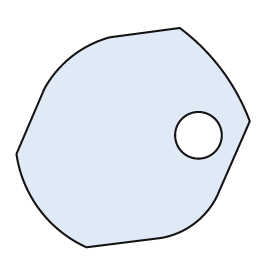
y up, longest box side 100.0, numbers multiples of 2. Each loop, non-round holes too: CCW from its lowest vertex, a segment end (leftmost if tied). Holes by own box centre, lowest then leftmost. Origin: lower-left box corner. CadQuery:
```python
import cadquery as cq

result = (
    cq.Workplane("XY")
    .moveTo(30.0, 0.0)
    .lineTo(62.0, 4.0)
    .threePointArc((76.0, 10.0), (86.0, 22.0))
    .lineTo(100.0, 54.0)
    .threePointArc((88.0, 76.0), (70.0, 94.0))
    .lineTo(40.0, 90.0)
    .threePointArc((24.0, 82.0), (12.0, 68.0))
    .lineTo(0.0, 40.0)
    .threePointArc((10.0, 16.0), (30.0, 0.0))
    .close()
    .moveTo(78.0, 48.0)
    .circle(10.0)
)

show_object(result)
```